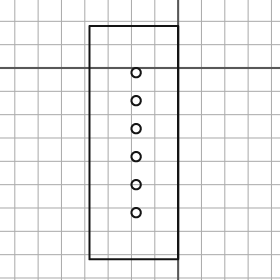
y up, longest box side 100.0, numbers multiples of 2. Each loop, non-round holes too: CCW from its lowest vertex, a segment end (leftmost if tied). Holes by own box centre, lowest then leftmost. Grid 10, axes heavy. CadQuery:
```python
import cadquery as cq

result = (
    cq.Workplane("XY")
    .moveTo(-38.0, -82.0)
    .lineTo(0.0, -82.0)
    .lineTo(0.0, 18.0)
    .lineTo(-38.0, 18.0)
    .close()
    .moveTo(-18.0, -62.0)
    .circle(2.0)
    .moveTo(-18.0, -50.0)
    .circle(2.0)
    .moveTo(-18.0, -38.0)
    .circle(2.0)
    .moveTo(-18.0, -26.0)
    .circle(2.0)
    .moveTo(-18.0, -14.0)
    .circle(2.0)
    .moveTo(-18.0, -2.0)
    .circle(2.0)
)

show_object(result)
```